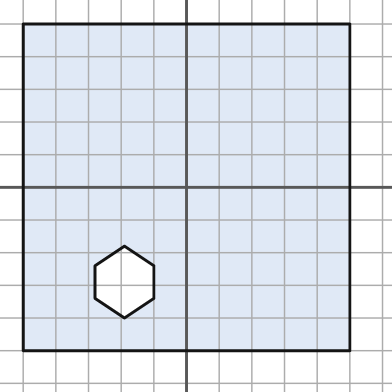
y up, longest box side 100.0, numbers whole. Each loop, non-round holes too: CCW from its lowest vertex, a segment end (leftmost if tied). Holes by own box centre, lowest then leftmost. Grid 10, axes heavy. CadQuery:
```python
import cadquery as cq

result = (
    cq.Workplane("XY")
    .moveTo(-50.0, -50.0)
    .lineTo(50.0, -50.0)
    .lineTo(50.0, 50.0)
    .lineTo(-50.0, 50.0)
    .close()
    .moveTo(-19.0, -40.0)
    .lineTo(-10.0, -34.0)
    .lineTo(-10.0, -24.0)
    .lineTo(-19.0, -18.0)
    .lineTo(-28.0, -24.0)
    .lineTo(-28.0, -34.0)
    .close()
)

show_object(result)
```